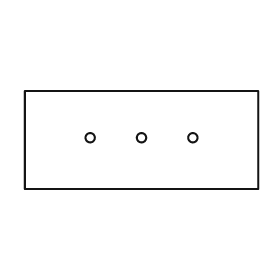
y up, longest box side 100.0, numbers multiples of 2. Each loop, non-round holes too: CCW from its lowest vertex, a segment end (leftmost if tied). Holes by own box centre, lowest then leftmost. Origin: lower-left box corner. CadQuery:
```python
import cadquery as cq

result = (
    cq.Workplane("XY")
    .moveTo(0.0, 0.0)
    .lineTo(100.0, 0.0)
    .lineTo(100.0, 42.0)
    .lineTo(0.0, 42.0)
    .close()
    .moveTo(28.0, 22.0)
    .circle(2.0)
    .moveTo(50.0, 22.0)
    .circle(2.0)
    .moveTo(72.0, 22.0)
    .circle(2.0)
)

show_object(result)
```